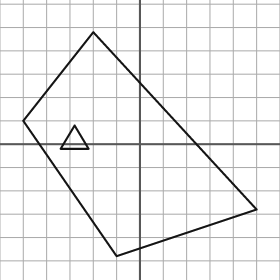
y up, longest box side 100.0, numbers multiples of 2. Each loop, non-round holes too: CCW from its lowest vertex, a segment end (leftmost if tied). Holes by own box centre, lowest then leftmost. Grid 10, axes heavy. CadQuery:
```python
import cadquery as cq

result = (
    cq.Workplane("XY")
    .moveTo(-10.0, -48.0)
    .lineTo(50.0, -28.0)
    .lineTo(-20.0, 48.0)
    .lineTo(-50.0, 10.0)
    .close()
    .moveTo(-34.0, -2.0)
    .lineTo(-22.0, -2.0)
    .lineTo(-28.0, 8.0)
    .close()
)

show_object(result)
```